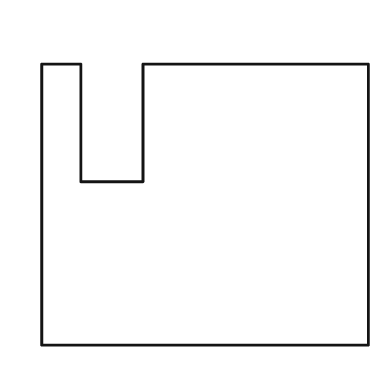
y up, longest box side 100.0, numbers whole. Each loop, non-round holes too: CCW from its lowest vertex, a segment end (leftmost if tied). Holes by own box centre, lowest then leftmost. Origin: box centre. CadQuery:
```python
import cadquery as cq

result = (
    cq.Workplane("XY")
    .moveTo(-50.0, -43.0)
    .lineTo(50.0, -43.0)
    .lineTo(50.0, 43.0)
    .lineTo(-19.0, 43.0)
    .lineTo(-19.0, 7.0)
    .lineTo(-38.0, 7.0)
    .lineTo(-38.0, 43.0)
    .lineTo(-50.0, 43.0)
    .close()
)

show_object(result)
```